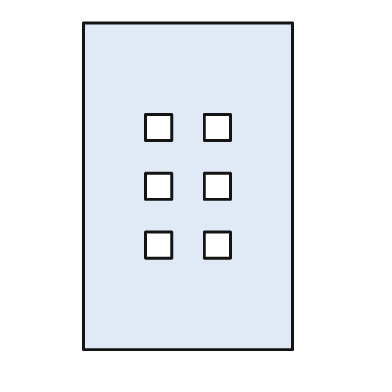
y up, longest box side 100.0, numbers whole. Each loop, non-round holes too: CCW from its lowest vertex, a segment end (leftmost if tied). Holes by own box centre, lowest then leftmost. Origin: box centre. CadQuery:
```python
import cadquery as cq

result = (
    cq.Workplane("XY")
    .moveTo(-32.0, -50.0)
    .lineTo(32.0, -50.0)
    .lineTo(32.0, 50.0)
    .lineTo(-32.0, 50.0)
    .close()
    .moveTo(-13.0, -22.0)
    .lineTo(-5.0, -22.0)
    .lineTo(-5.0, -14.0)
    .lineTo(-13.0, -14.0)
    .close()
    .moveTo(5.0, -22.0)
    .lineTo(13.0, -22.0)
    .lineTo(13.0, -14.0)
    .lineTo(5.0, -14.0)
    .close()
    .moveTo(-13.0, -4.0)
    .lineTo(-5.0, -4.0)
    .lineTo(-5.0, 4.0)
    .lineTo(-13.0, 4.0)
    .close()
    .moveTo(5.0, -4.0)
    .lineTo(13.0, -4.0)
    .lineTo(13.0, 4.0)
    .lineTo(5.0, 4.0)
    .close()
    .moveTo(-13.0, 14.0)
    .lineTo(-5.0, 14.0)
    .lineTo(-5.0, 22.0)
    .lineTo(-13.0, 22.0)
    .close()
    .moveTo(5.0, 14.0)
    .lineTo(13.0, 14.0)
    .lineTo(13.0, 22.0)
    .lineTo(5.0, 22.0)
    .close()
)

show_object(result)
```